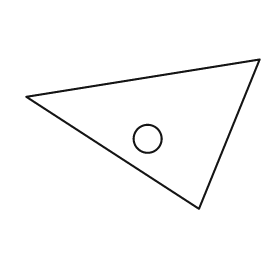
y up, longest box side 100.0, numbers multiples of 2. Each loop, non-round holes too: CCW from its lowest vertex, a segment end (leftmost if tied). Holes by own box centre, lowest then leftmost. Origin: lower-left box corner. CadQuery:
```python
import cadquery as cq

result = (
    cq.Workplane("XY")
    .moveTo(74.0, 0.0)
    .lineTo(100.0, 64.0)
    .lineTo(0.0, 48.0)
    .close()
    .moveTo(52.0, 30.0)
    .circle(6.0)
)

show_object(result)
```